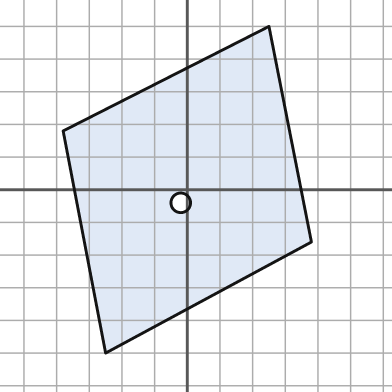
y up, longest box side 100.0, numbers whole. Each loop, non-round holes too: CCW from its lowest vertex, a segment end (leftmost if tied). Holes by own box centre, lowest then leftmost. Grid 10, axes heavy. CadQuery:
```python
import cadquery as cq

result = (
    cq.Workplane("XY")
    .moveTo(-25.0, -50.0)
    .lineTo(38.0, -16.0)
    .lineTo(25.0, 50.0)
    .lineTo(-38.0, 18.0)
    .close()
    .moveTo(-2.0, -4.0)
    .circle(3.0)
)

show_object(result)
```